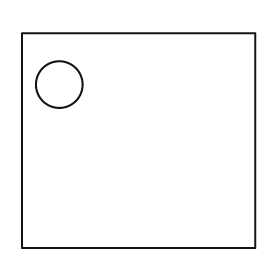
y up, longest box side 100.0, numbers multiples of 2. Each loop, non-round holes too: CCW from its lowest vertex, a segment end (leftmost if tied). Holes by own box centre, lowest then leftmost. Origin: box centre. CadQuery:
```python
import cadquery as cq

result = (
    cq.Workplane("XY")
    .moveTo(-50.0, -46.0)
    .lineTo(50.0, -46.0)
    .lineTo(50.0, 46.0)
    .lineTo(-50.0, 46.0)
    .close()
    .moveTo(-34.0, 24.0)
    .circle(10.0)
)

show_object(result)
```